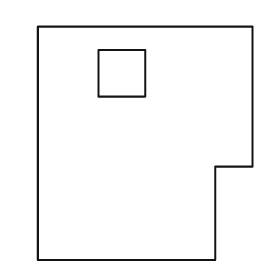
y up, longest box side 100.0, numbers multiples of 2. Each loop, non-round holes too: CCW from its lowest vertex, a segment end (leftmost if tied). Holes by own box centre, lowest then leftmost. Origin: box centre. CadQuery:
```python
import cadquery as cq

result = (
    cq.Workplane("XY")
    .moveTo(-46.0, -50.0)
    .lineTo(30.0, -50.0)
    .lineTo(30.0, -10.0)
    .lineTo(46.0, -10.0)
    .lineTo(46.0, 50.0)
    .lineTo(-46.0, 50.0)
    .close()
    .moveTo(-20.0, 20.0)
    .lineTo(0.0, 20.0)
    .lineTo(0.0, 40.0)
    .lineTo(-20.0, 40.0)
    .close()
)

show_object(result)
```